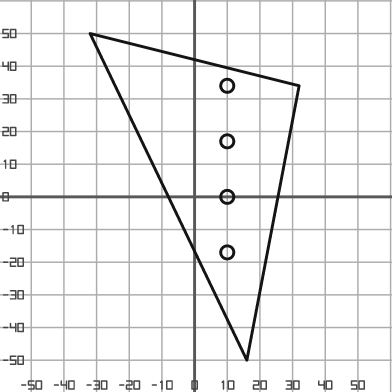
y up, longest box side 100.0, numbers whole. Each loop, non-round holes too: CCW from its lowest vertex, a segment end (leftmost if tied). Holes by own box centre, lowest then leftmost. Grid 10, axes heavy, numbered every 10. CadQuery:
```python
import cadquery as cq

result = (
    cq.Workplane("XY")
    .moveTo(16.0, -50.0)
    .lineTo(32.0, 34.0)
    .lineTo(-32.0, 50.0)
    .close()
    .moveTo(10.0, -17.0)
    .circle(2.0)
    .moveTo(10.0, 0.0)
    .circle(2.0)
    .moveTo(10.0, 17.0)
    .circle(2.0)
    .moveTo(10.0, 34.0)
    .circle(2.0)
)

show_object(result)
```